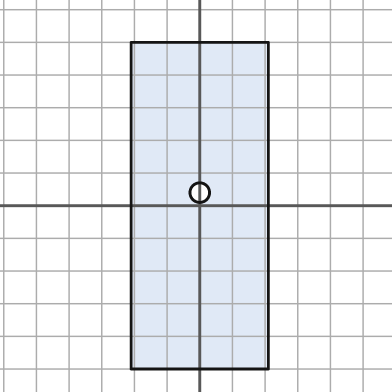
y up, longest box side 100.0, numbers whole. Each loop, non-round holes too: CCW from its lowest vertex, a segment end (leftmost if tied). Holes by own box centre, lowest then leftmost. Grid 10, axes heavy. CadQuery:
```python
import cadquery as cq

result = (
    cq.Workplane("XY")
    .moveTo(-21.0, -50.0)
    .lineTo(21.0, -50.0)
    .lineTo(21.0, 50.0)
    .lineTo(-21.0, 50.0)
    .close()
    .moveTo(0.0, 4.0)
    .circle(3.0)
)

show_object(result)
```